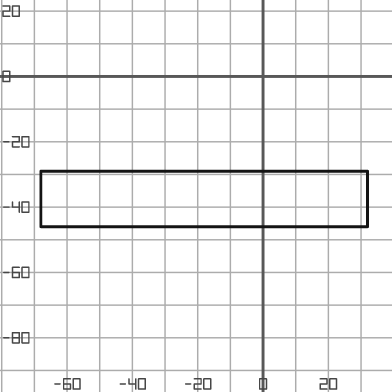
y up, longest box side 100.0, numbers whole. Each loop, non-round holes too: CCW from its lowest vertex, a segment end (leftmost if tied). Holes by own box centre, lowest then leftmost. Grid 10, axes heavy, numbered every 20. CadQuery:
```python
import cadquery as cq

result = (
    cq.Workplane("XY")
    .moveTo(-68.0, -46.0)
    .lineTo(32.0, -46.0)
    .lineTo(32.0, -29.0)
    .lineTo(-68.0, -29.0)
    .close()
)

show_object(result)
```